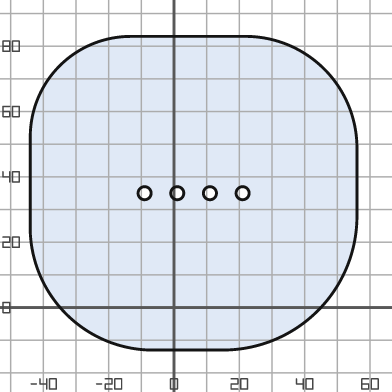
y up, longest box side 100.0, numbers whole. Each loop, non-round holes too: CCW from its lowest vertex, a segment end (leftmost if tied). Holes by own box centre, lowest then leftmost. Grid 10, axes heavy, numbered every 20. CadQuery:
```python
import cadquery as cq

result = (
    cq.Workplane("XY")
    .moveTo(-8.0, -13.0)
    .lineTo(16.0, -13.0)
    .threePointArc((44.0, -1.0), (56.0, 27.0))
    .lineTo(56.0, 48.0)
    .threePointArc((46.0, 73.0), (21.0, 83.0))
    .lineTo(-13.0, 83.0)
    .threePointArc((-35.0, 74.0), (-44.0, 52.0))
    .lineTo(-44.0, 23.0)
    .threePointArc((-33.0, -2.0), (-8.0, -13.0))
    .close()
    .moveTo(-9.0, 35.0)
    .circle(2.0)
    .moveTo(1.0, 35.0)
    .circle(2.0)
    .moveTo(11.0, 35.0)
    .circle(2.0)
    .moveTo(21.0, 35.0)
    .circle(2.0)
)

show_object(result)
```